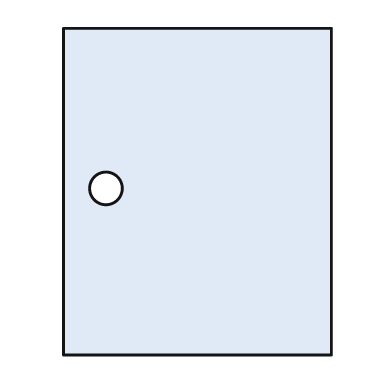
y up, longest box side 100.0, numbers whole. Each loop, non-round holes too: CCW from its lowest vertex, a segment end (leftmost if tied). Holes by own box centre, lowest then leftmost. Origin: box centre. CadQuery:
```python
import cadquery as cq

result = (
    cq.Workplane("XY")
    .moveTo(-41.0, -50.0)
    .lineTo(41.0, -50.0)
    .lineTo(41.0, 50.0)
    .lineTo(-41.0, 50.0)
    .close()
    .moveTo(-28.0, 1.0)
    .circle(5.0)
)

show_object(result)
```